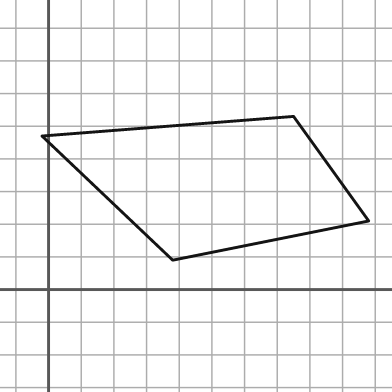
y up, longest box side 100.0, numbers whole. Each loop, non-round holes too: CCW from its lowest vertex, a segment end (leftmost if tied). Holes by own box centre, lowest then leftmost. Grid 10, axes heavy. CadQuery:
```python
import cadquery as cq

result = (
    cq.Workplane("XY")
    .moveTo(38.0, 9.0)
    .lineTo(98.0, 21.0)
    .lineTo(75.0, 53.0)
    .lineTo(-2.0, 47.0)
    .close()
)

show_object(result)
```